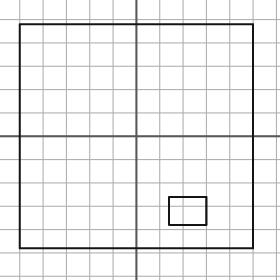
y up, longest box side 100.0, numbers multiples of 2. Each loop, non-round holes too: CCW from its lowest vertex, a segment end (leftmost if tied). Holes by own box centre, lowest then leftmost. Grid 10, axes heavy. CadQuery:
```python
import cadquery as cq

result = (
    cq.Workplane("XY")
    .moveTo(-50.0, -48.0)
    .lineTo(50.0, -48.0)
    .lineTo(50.0, 48.0)
    .lineTo(-50.0, 48.0)
    .close()
    .moveTo(14.0, -38.0)
    .lineTo(30.0, -38.0)
    .lineTo(30.0, -26.0)
    .lineTo(14.0, -26.0)
    .close()
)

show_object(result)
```